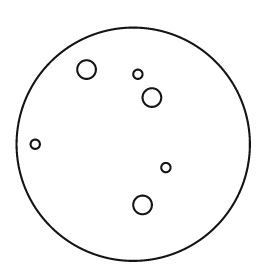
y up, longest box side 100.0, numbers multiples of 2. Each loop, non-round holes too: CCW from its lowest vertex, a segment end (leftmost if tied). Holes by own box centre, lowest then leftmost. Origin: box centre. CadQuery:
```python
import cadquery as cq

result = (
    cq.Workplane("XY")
    .moveTo(0.0, 0.0)
    .circle(50.0)
    .moveTo(4.0, -26.0)
    .circle(4.0)
    .moveTo(14.0, -10.0)
    .circle(2.0)
    .moveTo(-42.0, 0.0)
    .circle(2.0)
    .moveTo(8.0, 20.0)
    .circle(4.0)
    .moveTo(2.0, 30.0)
    .circle(2.0)
    .moveTo(-20.0, 32.0)
    .circle(4.0)
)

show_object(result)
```